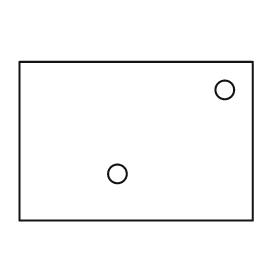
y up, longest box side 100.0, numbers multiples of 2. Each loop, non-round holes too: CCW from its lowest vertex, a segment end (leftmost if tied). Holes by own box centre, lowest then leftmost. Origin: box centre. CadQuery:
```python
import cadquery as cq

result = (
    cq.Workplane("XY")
    .moveTo(-50.0, -34.0)
    .lineTo(50.0, -34.0)
    .lineTo(50.0, 34.0)
    .lineTo(-50.0, 34.0)
    .close()
    .moveTo(-8.0, -14.0)
    .circle(4.0)
    .moveTo(38.0, 22.0)
    .circle(4.0)
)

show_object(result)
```